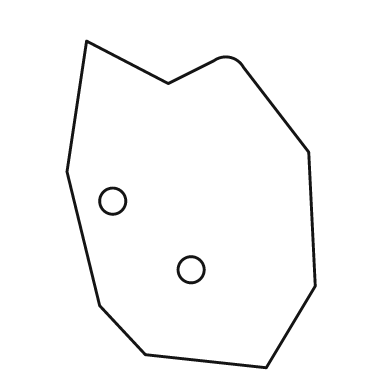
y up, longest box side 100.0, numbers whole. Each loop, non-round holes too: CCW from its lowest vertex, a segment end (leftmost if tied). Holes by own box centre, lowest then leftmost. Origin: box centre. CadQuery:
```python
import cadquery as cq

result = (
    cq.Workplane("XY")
    .moveTo(23.0, -50.0)
    .lineTo(38.0, -25.0)
    .lineTo(36.0, 16.0)
    .lineTo(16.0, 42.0)
    .threePointArc((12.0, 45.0), (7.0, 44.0))
    .lineTo(-7.0, 37.0)
    .lineTo(-32.0, 50.0)
    .lineTo(-38.0, 10.0)
    .lineTo(-28.0, -31.0)
    .lineTo(-14.0, -46.0)
    .close()
    .moveTo(0.0, -20.0)
    .circle(4.0)
    .moveTo(-24.0, 1.0)
    .circle(4.0)
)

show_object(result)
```